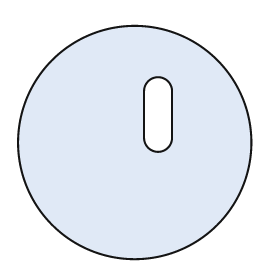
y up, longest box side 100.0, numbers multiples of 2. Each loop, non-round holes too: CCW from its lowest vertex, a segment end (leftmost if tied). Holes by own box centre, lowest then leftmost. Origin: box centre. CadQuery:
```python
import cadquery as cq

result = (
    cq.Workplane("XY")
    .moveTo(0.0, 0.0)
    .circle(50.0)
    .moveTo(4.0, 2.0)
    .threePointArc((10.0, -4.0), (16.0, 2.0))
    .lineTo(16.0, 22.0)
    .threePointArc((10.0, 28.0), (4.0, 22.0))
    .close()
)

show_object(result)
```